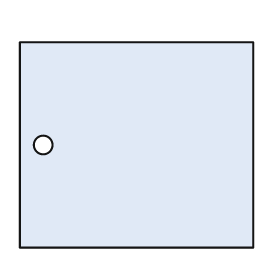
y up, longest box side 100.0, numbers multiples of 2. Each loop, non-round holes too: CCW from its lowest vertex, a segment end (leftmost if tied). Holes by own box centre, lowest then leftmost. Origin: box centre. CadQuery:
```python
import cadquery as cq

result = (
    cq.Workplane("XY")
    .moveTo(-50.0, -44.0)
    .lineTo(50.0, -44.0)
    .lineTo(50.0, 44.0)
    .lineTo(-50.0, 44.0)
    .close()
    .moveTo(-40.0, 0.0)
    .circle(4.0)
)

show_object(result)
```